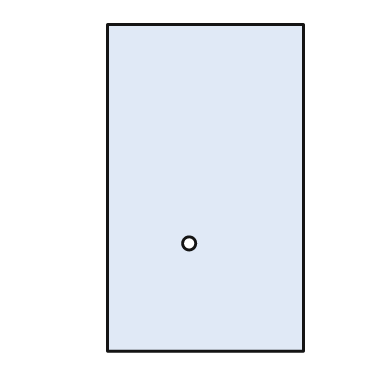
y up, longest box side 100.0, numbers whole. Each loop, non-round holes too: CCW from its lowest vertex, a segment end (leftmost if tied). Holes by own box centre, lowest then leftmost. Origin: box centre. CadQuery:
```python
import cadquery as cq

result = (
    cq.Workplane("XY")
    .moveTo(-30.0, -50.0)
    .lineTo(30.0, -50.0)
    .lineTo(30.0, 50.0)
    .lineTo(-30.0, 50.0)
    .close()
    .moveTo(-5.0, -17.0)
    .circle(2.0)
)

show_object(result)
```